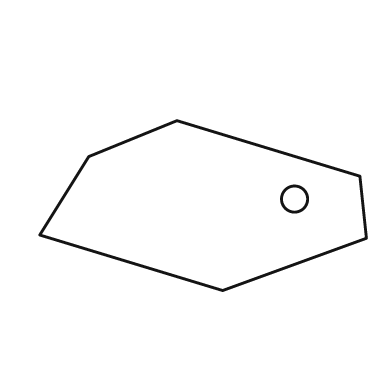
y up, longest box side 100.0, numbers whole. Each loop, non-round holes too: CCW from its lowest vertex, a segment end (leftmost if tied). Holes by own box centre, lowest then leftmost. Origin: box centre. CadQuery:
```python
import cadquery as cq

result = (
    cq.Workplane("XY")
    .moveTo(6.0, -26.0)
    .lineTo(50.0, -10.0)
    .lineTo(48.0, 9.0)
    .lineTo(-8.0, 26.0)
    .lineTo(-35.0, 15.0)
    .lineTo(-50.0, -9.0)
    .close()
    .moveTo(28.0, 2.0)
    .circle(4.0)
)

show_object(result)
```